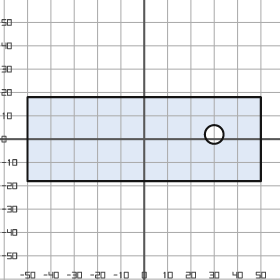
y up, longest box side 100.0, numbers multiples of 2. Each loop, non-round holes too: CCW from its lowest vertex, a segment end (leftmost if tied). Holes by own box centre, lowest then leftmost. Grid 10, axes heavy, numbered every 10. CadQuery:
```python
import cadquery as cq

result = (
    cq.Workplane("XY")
    .moveTo(-50.0, -18.0)
    .lineTo(50.0, -18.0)
    .lineTo(50.0, 18.0)
    .lineTo(-50.0, 18.0)
    .close()
    .moveTo(30.0, 2.0)
    .circle(4.0)
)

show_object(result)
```